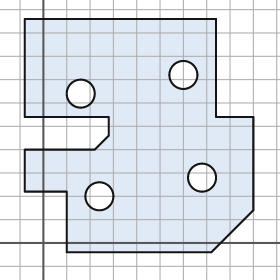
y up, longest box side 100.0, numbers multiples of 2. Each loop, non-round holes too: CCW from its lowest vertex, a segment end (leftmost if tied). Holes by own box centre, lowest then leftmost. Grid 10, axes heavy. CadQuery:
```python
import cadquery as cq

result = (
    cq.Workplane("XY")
    .moveTo(10.0, -4.0)
    .lineTo(72.0, -4.0)
    .lineTo(90.0, 14.0)
    .lineTo(90.0, 54.0)
    .lineTo(74.0, 54.0)
    .lineTo(74.0, 96.0)
    .lineTo(-8.0, 96.0)
    .lineTo(-8.0, 54.0)
    .lineTo(28.0, 54.0)
    .lineTo(28.0, 46.0)
    .lineTo(22.0, 40.0)
    .lineTo(-8.0, 40.0)
    .lineTo(-8.0, 22.0)
    .lineTo(10.0, 22.0)
    .close()
    .moveTo(24.0, 20.0)
    .circle(6.0)
    .moveTo(68.0, 28.0)
    .circle(6.0)
    .moveTo(16.0, 64.0)
    .circle(6.0)
    .moveTo(60.0, 72.0)
    .circle(6.0)
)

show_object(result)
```